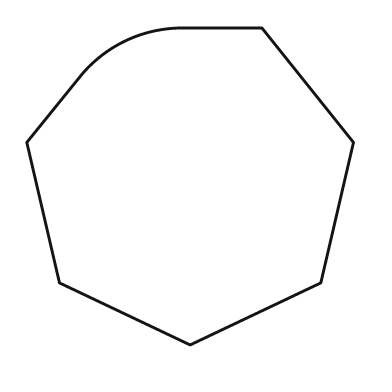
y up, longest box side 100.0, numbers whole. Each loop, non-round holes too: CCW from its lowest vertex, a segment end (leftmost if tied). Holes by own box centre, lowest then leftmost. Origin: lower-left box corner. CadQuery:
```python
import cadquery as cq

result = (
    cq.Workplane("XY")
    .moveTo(50.0, 0.0)
    .lineTo(90.0, 19.0)
    .lineTo(100.0, 62.0)
    .lineTo(72.0, 97.0)
    .lineTo(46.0, 97.0)
    .threePointArc((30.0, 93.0), (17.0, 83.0))
    .lineTo(0.0, 62.0)
    .lineTo(10.0, 19.0)
    .close()
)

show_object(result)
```